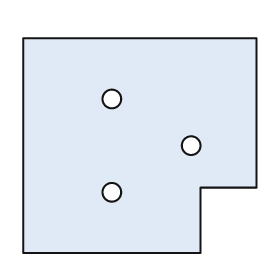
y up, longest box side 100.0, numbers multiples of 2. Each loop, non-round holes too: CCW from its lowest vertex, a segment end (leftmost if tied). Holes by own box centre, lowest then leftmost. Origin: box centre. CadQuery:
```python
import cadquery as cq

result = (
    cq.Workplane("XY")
    .moveTo(-50.0, -46.0)
    .lineTo(26.0, -46.0)
    .lineTo(26.0, -18.0)
    .lineTo(50.0, -18.0)
    .lineTo(50.0, 46.0)
    .lineTo(-50.0, 46.0)
    .close()
    .moveTo(-12.0, -20.0)
    .circle(4.0)
    .moveTo(22.0, 0.0)
    .circle(4.0)
    .moveTo(-12.0, 20.0)
    .circle(4.0)
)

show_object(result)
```